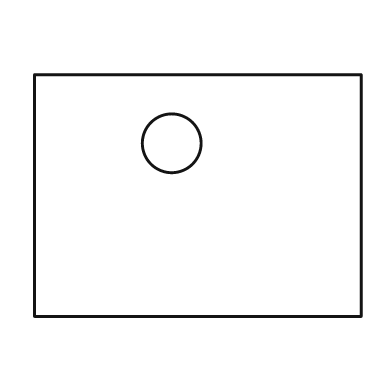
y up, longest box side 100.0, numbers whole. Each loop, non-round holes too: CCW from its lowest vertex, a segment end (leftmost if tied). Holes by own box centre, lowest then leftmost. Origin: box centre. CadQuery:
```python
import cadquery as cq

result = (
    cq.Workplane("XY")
    .moveTo(-50.0, -37.0)
    .lineTo(50.0, -37.0)
    .lineTo(50.0, 37.0)
    .lineTo(-50.0, 37.0)
    .close()
    .moveTo(-8.0, 16.0)
    .circle(9.0)
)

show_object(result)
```